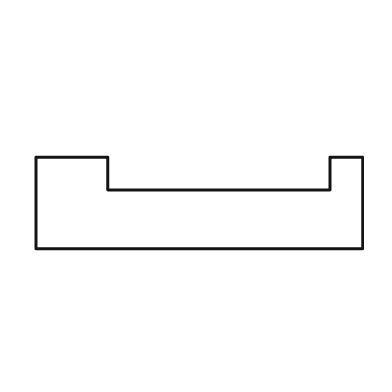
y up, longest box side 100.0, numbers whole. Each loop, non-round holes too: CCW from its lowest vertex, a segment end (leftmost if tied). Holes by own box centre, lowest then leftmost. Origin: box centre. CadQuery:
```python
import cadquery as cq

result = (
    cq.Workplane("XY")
    .moveTo(-50.0, -14.0)
    .lineTo(50.0, -14.0)
    .lineTo(50.0, 14.0)
    .lineTo(40.0, 14.0)
    .lineTo(40.0, 4.0)
    .lineTo(-28.0, 4.0)
    .lineTo(-28.0, 14.0)
    .lineTo(-50.0, 14.0)
    .close()
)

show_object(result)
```